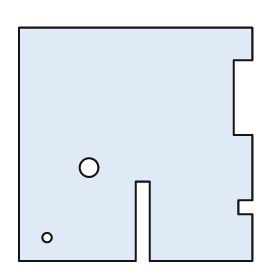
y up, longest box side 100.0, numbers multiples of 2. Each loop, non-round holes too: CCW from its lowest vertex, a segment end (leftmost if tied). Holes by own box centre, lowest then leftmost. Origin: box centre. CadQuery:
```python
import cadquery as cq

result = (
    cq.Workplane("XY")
    .moveTo(-50.0, -50.0)
    .lineTo(0.0, -50.0)
    .lineTo(0.0, -16.0)
    .lineTo(6.0, -16.0)
    .lineTo(6.0, -50.0)
    .lineTo(50.0, -50.0)
    .lineTo(50.0, -30.0)
    .lineTo(44.0, -30.0)
    .lineTo(44.0, -24.0)
    .lineTo(50.0, -24.0)
    .lineTo(50.0, 4.0)
    .lineTo(42.0, 4.0)
    .lineTo(42.0, 36.0)
    .lineTo(50.0, 36.0)
    .lineTo(50.0, 50.0)
    .lineTo(-50.0, 50.0)
    .close()
    .moveTo(-38.0, -40.0)
    .circle(2.0)
    .moveTo(-20.0, -10.0)
    .circle(4.0)
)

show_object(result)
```